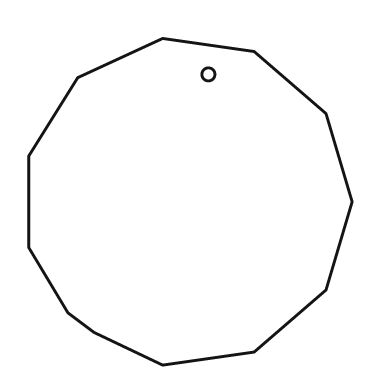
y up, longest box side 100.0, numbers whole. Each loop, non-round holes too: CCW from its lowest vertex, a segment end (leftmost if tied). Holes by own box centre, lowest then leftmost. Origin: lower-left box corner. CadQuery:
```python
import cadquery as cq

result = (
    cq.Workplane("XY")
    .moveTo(41.0, 0.0)
    .lineTo(69.0, 4.0)
    .lineTo(91.0, 23.0)
    .lineTo(99.0, 50.0)
    .lineTo(91.0, 77.0)
    .lineTo(69.0, 96.0)
    .lineTo(41.0, 100.0)
    .lineTo(15.0, 88.0)
    .lineTo(0.0, 64.0)
    .lineTo(0.0, 36.0)
    .lineTo(12.0, 16.0)
    .lineTo(20.0, 10.0)
    .close()
    .moveTo(55.0, 89.0)
    .circle(2.0)
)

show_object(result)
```